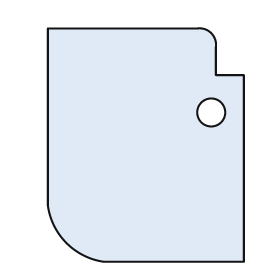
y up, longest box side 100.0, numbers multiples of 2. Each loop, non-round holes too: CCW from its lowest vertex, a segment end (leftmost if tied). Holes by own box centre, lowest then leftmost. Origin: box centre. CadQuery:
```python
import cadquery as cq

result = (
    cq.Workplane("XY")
    .moveTo(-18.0, -50.0)
    .lineTo(42.0, -50.0)
    .lineTo(42.0, 30.0)
    .lineTo(30.0, 30.0)
    .lineTo(30.0, 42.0)
    .threePointArc((28.0, 48.0), (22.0, 50.0))
    .lineTo(-42.0, 50.0)
    .lineTo(-42.0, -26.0)
    .threePointArc((-34.0, -42.0), (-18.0, -50.0))
    .close()
    .moveTo(28.0, 14.0)
    .circle(6.0)
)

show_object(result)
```